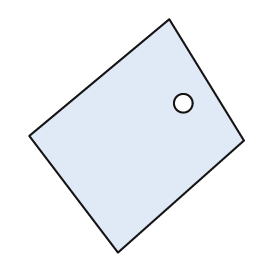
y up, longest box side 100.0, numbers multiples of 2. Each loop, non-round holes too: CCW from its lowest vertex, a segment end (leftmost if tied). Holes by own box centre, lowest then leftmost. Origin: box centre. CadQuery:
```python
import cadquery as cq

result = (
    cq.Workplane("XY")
    .moveTo(-8.0, -50.0)
    .lineTo(46.0, -2.0)
    .lineTo(14.0, 50.0)
    .lineTo(-46.0, 0.0)
    .close()
    .moveTo(20.0, 14.0)
    .circle(4.0)
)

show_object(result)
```